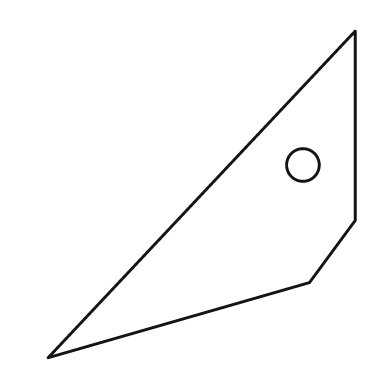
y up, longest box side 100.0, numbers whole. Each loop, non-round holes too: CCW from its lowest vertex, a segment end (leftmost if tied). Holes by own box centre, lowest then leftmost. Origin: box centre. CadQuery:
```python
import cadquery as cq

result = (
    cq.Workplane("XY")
    .moveTo(-47.0, -50.0)
    .lineTo(33.0, -27.0)
    .lineTo(47.0, -8.0)
    .lineTo(47.0, 50.0)
    .close()
    .moveTo(31.0, 9.0)
    .circle(5.0)
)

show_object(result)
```